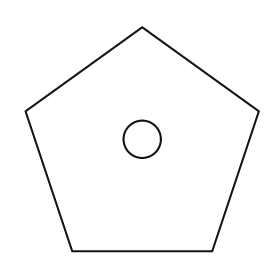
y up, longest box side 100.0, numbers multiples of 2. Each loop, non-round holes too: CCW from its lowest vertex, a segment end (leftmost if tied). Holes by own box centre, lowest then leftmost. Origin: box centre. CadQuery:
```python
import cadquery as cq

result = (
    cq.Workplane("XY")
    .moveTo(-30.0, -48.0)
    .lineTo(30.0, -48.0)
    .lineTo(50.0, 12.0)
    .lineTo(0.0, 48.0)
    .lineTo(-50.0, 12.0)
    .close()
    .moveTo(0.0, 0.0)
    .circle(8.0)
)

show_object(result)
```